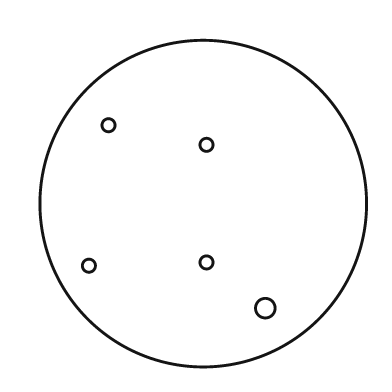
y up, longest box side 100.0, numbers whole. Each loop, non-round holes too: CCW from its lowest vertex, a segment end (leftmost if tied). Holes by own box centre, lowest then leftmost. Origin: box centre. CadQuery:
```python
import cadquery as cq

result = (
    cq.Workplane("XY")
    .moveTo(0.0, 0.0)
    .circle(50.0)
    .moveTo(19.0, -32.0)
    .circle(3.0)
    .moveTo(-35.0, -19.0)
    .circle(2.0)
    .moveTo(1.0, -18.0)
    .circle(2.0)
    .moveTo(1.0, 18.0)
    .circle(2.0)
    .moveTo(-29.0, 24.0)
    .circle(2.0)
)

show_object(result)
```